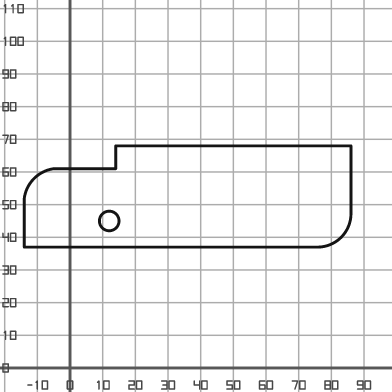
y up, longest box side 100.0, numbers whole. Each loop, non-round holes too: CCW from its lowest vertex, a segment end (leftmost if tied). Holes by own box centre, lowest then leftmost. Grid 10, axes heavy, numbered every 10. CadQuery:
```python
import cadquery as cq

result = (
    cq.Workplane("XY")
    .moveTo(-14.0, 37.0)
    .lineTo(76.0, 37.0)
    .threePointArc((83.0, 40.0), (86.0, 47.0))
    .lineTo(86.0, 68.0)
    .lineTo(14.0, 68.0)
    .lineTo(14.0, 61.0)
    .lineTo(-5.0, 61.0)
    .threePointArc((-11.0, 58.0), (-14.0, 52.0))
    .close()
    .moveTo(12.0, 45.0)
    .circle(3.0)
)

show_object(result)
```